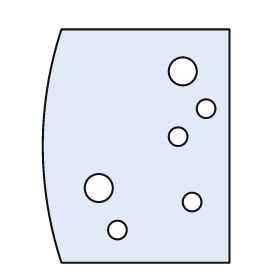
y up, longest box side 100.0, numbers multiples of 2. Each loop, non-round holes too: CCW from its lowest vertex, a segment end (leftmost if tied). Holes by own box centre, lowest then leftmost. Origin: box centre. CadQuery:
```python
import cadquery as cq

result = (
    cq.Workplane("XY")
    .moveTo(-32.0, -50.0)
    .lineTo(40.0, -50.0)
    .lineTo(40.0, 50.0)
    .lineTo(-32.0, 50.0)
    .threePointArc((-40.0, 0.0), (-32.0, -50.0))
    .close()
    .moveTo(-8.0, -36.0)
    .circle(4.0)
    .moveTo(24.0, -24.0)
    .circle(4.0)
    .moveTo(-16.0, -18.0)
    .circle(6.0)
    .moveTo(18.0, 4.0)
    .circle(4.0)
    .moveTo(30.0, 16.0)
    .circle(4.0)
    .moveTo(20.0, 32.0)
    .circle(6.0)
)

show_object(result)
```